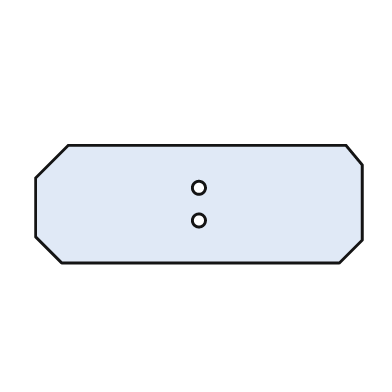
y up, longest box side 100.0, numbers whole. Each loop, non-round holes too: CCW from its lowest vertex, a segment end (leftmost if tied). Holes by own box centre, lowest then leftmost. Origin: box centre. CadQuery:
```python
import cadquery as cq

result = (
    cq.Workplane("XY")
    .moveTo(-42.0, -18.0)
    .lineTo(43.0, -18.0)
    .lineTo(50.0, -11.0)
    .lineTo(50.0, 12.0)
    .lineTo(45.0, 18.0)
    .lineTo(-40.0, 18.0)
    .lineTo(-50.0, 8.0)
    .lineTo(-50.0, -10.0)
    .close()
    .moveTo(0.0, -5.0)
    .circle(2.0)
    .moveTo(0.0, 5.0)
    .circle(2.0)
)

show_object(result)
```